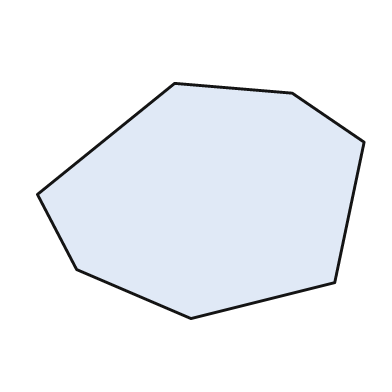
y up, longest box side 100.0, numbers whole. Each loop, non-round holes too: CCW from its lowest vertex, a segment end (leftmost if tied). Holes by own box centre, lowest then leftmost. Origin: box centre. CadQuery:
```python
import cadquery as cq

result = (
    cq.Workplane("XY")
    .moveTo(-3.0, -36.0)
    .lineTo(41.0, -25.0)
    .lineTo(50.0, 18.0)
    .lineTo(28.0, 33.0)
    .lineTo(-8.0, 36.0)
    .lineTo(-50.0, 2.0)
    .lineTo(-38.0, -21.0)
    .close()
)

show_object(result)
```